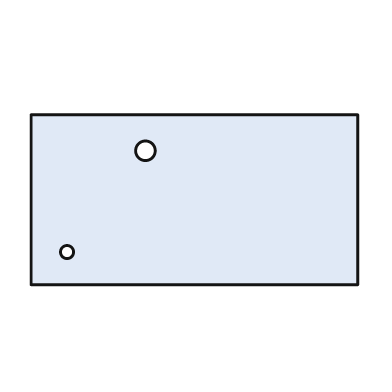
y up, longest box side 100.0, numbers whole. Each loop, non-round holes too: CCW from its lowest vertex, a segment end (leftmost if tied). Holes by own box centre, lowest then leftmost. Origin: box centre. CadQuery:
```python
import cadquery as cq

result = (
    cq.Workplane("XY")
    .moveTo(-50.0, -26.0)
    .lineTo(50.0, -26.0)
    .lineTo(50.0, 26.0)
    .lineTo(-50.0, 26.0)
    .close()
    .moveTo(-39.0, -16.0)
    .circle(2.0)
    .moveTo(-15.0, 15.0)
    .circle(3.0)
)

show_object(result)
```